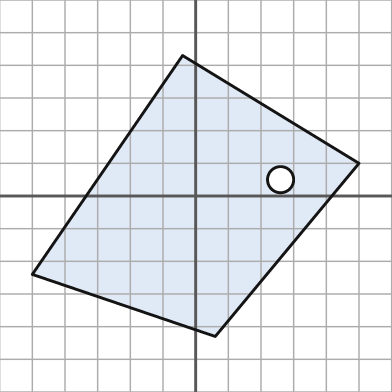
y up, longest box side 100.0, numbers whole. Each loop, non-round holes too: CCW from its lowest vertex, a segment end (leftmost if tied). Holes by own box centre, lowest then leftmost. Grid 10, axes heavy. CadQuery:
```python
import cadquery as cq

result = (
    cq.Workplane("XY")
    .moveTo(6.0, -43.0)
    .lineTo(50.0, 10.0)
    .lineTo(-4.0, 43.0)
    .lineTo(-50.0, -24.0)
    .close()
    .moveTo(26.0, 5.0)
    .circle(4.0)
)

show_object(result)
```